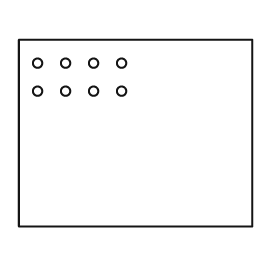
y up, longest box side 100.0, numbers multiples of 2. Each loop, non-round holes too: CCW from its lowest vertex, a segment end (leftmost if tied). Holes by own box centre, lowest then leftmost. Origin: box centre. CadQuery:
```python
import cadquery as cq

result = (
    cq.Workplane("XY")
    .moveTo(-50.0, -40.0)
    .lineTo(50.0, -40.0)
    .lineTo(50.0, 40.0)
    .lineTo(-50.0, 40.0)
    .close()
    .moveTo(-42.0, 18.0)
    .circle(2.0)
    .moveTo(-30.0, 18.0)
    .circle(2.0)
    .moveTo(-18.0, 18.0)
    .circle(2.0)
    .moveTo(-6.0, 18.0)
    .circle(2.0)
    .moveTo(-42.0, 30.0)
    .circle(2.0)
    .moveTo(-30.0, 30.0)
    .circle(2.0)
    .moveTo(-18.0, 30.0)
    .circle(2.0)
    .moveTo(-6.0, 30.0)
    .circle(2.0)
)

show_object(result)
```